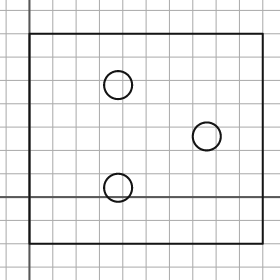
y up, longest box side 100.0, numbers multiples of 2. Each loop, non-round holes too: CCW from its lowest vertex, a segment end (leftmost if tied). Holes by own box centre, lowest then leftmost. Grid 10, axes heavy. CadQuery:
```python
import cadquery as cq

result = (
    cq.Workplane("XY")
    .moveTo(0.0, -20.0)
    .lineTo(100.0, -20.0)
    .lineTo(100.0, 70.0)
    .lineTo(0.0, 70.0)
    .close()
    .moveTo(38.0, 4.0)
    .circle(6.0)
    .moveTo(76.0, 26.0)
    .circle(6.0)
    .moveTo(38.0, 48.0)
    .circle(6.0)
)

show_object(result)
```